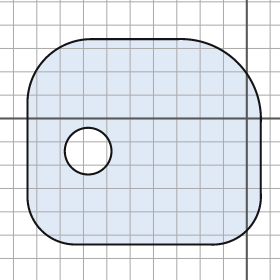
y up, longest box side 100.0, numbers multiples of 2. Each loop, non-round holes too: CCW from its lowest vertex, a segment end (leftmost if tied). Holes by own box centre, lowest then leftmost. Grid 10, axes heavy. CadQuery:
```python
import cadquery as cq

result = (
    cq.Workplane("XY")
    .moveTo(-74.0, -54.0)
    .lineTo(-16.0, -54.0)
    .threePointArc((0.0, -48.0), (6.0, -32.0))
    .lineTo(6.0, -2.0)
    .threePointArc((-4.0, 24.0), (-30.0, 34.0))
    .lineTo(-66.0, 34.0)
    .threePointArc((-86.0, 26.0), (-94.0, 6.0))
    .lineTo(-94.0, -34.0)
    .threePointArc((-88.0, -48.0), (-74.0, -54.0))
    .close()
    .moveTo(-68.0, -14.0)
    .circle(10.0)
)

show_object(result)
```